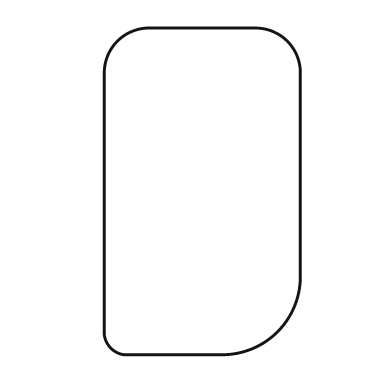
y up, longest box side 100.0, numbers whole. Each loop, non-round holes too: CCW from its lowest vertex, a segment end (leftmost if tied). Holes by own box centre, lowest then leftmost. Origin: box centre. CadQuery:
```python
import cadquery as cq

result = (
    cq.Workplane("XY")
    .moveTo(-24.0, -50.0)
    .lineTo(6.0, -50.0)
    .threePointArc((23.0, -43.0), (30.0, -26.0))
    .lineTo(30.0, 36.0)
    .threePointArc((26.0, 46.0), (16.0, 50.0))
    .lineTo(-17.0, 50.0)
    .threePointArc((-26.0, 46.0), (-30.0, 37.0))
    .lineTo(-30.0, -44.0)
    .threePointArc((-28.0, -48.0), (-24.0, -50.0))
    .close()
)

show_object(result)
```